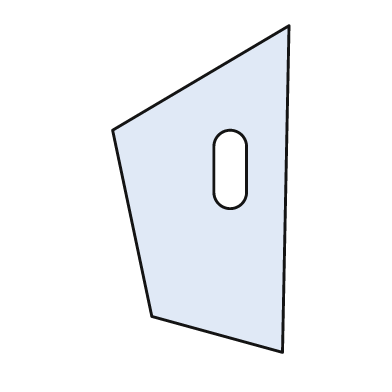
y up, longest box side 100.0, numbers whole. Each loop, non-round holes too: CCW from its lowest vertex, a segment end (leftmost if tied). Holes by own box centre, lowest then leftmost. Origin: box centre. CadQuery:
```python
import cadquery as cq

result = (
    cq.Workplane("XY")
    .moveTo(25.0, -50.0)
    .lineTo(27.0, 50.0)
    .lineTo(-27.0, 18.0)
    .lineTo(-15.0, -39.0)
    .close()
    .moveTo(4.0, -1.0)
    .threePointArc((9.0, -6.0), (14.0, -1.0))
    .lineTo(14.0, 13.0)
    .threePointArc((9.0, 18.0), (4.0, 13.0))
    .close()
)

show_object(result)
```